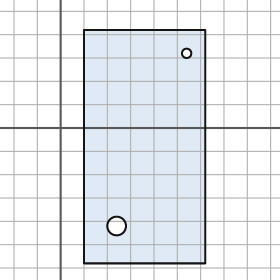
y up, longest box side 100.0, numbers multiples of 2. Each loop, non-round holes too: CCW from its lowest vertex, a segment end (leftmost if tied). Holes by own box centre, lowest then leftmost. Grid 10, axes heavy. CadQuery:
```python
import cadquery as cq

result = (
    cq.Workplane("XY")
    .moveTo(10.0, -58.0)
    .lineTo(62.0, -58.0)
    .lineTo(62.0, 42.0)
    .lineTo(10.0, 42.0)
    .close()
    .moveTo(24.0, -42.0)
    .circle(4.0)
    .moveTo(54.0, 32.0)
    .circle(2.0)
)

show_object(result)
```